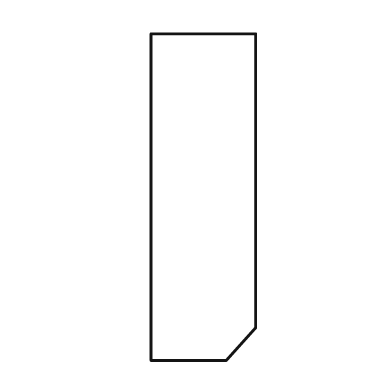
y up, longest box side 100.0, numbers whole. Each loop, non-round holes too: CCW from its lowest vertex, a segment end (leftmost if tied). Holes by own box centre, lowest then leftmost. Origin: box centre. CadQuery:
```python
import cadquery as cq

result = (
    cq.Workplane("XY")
    .moveTo(-16.0, -50.0)
    .lineTo(7.0, -50.0)
    .lineTo(16.0, -40.0)
    .lineTo(16.0, 50.0)
    .lineTo(-16.0, 50.0)
    .close()
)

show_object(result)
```